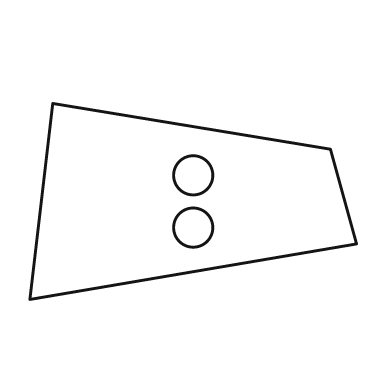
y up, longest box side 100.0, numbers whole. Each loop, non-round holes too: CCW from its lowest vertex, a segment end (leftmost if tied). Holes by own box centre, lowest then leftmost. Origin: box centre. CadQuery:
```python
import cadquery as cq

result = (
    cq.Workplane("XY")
    .moveTo(-50.0, -30.0)
    .lineTo(50.0, -13.0)
    .lineTo(42.0, 16.0)
    .lineTo(-43.0, 30.0)
    .close()
    .moveTo(0.0, -8.0)
    .circle(6.0)
    .moveTo(0.0, 8.0)
    .circle(6.0)
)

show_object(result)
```